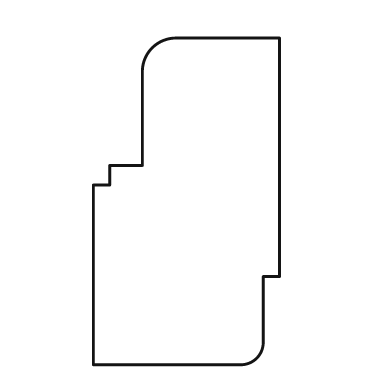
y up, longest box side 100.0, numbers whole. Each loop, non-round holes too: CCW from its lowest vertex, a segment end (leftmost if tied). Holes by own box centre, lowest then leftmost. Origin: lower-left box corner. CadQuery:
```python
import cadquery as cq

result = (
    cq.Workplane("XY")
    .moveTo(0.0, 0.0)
    .lineTo(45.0, 0.0)
    .threePointArc((50.0, 2.0), (52.0, 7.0))
    .lineTo(52.0, 27.0)
    .lineTo(57.0, 27.0)
    .lineTo(57.0, 100.0)
    .lineTo(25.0, 100.0)
    .threePointArc((18.0, 97.0), (15.0, 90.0))
    .lineTo(15.0, 61.0)
    .lineTo(5.0, 61.0)
    .lineTo(5.0, 55.0)
    .lineTo(0.0, 55.0)
    .close()
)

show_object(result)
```